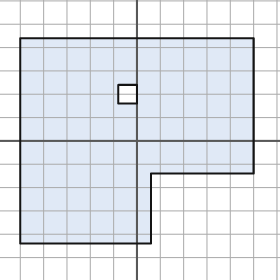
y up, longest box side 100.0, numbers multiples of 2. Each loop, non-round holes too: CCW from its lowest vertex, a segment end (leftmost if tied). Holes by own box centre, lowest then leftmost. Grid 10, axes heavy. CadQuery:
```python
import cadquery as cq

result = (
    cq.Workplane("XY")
    .moveTo(-50.0, -44.0)
    .lineTo(6.0, -44.0)
    .lineTo(6.0, -14.0)
    .lineTo(50.0, -14.0)
    .lineTo(50.0, 44.0)
    .lineTo(-50.0, 44.0)
    .close()
    .moveTo(-8.0, 16.0)
    .lineTo(0.0, 16.0)
    .lineTo(0.0, 24.0)
    .lineTo(-8.0, 24.0)
    .close()
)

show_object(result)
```